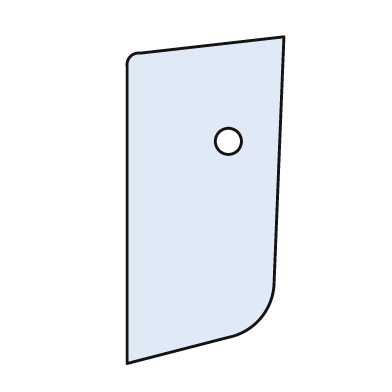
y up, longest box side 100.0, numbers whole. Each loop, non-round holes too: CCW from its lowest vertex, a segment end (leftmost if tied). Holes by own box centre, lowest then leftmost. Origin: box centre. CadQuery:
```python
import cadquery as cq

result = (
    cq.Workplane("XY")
    .moveTo(-24.0, -50.0)
    .lineTo(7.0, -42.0)
    .threePointArc((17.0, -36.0), (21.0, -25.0))
    .lineTo(24.0, 50.0)
    .lineTo(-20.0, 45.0)
    .threePointArc((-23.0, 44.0), (-24.0, 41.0))
    .close()
    .moveTo(7.0, 18.0)
    .circle(4.0)
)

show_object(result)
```